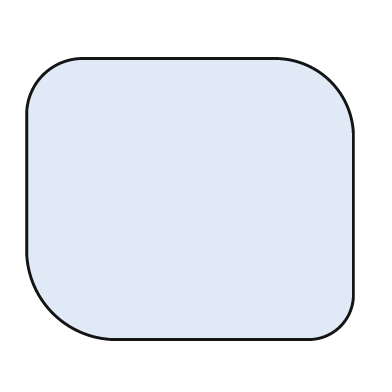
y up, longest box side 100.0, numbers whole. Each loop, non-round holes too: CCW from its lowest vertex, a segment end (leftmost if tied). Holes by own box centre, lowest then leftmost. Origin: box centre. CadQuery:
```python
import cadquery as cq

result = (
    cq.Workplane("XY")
    .moveTo(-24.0, -43.0)
    .lineTo(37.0, -43.0)
    .threePointArc((46.0, -39.0), (50.0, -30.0))
    .lineTo(50.0, 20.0)
    .threePointArc((43.0, 36.0), (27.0, 43.0))
    .lineTo(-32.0, 43.0)
    .threePointArc((-45.0, 38.0), (-50.0, 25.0))
    .lineTo(-50.0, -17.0)
    .threePointArc((-42.0, -35.0), (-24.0, -43.0))
    .close()
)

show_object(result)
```